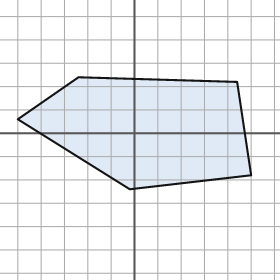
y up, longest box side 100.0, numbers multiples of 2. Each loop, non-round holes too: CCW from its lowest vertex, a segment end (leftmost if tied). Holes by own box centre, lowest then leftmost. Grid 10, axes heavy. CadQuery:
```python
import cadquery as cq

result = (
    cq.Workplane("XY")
    .moveTo(-2.0, -24.0)
    .lineTo(50.0, -18.0)
    .lineTo(44.0, 22.0)
    .lineTo(-24.0, 24.0)
    .lineTo(-50.0, 6.0)
    .close()
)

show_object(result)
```